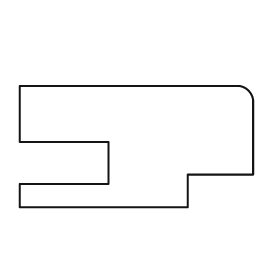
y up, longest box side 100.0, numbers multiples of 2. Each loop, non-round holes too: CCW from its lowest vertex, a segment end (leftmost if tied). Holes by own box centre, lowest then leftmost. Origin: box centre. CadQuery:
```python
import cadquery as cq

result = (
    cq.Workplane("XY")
    .moveTo(-50.0, -26.0)
    .lineTo(22.0, -26.0)
    .lineTo(22.0, -12.0)
    .lineTo(50.0, -12.0)
    .lineTo(50.0, 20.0)
    .threePointArc((48.0, 24.0), (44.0, 26.0))
    .lineTo(-50.0, 26.0)
    .lineTo(-50.0, 2.0)
    .lineTo(-12.0, 2.0)
    .lineTo(-12.0, -16.0)
    .lineTo(-50.0, -16.0)
    .close()
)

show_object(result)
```